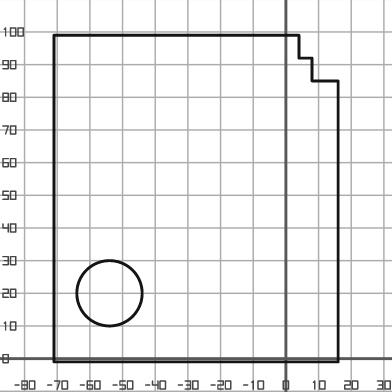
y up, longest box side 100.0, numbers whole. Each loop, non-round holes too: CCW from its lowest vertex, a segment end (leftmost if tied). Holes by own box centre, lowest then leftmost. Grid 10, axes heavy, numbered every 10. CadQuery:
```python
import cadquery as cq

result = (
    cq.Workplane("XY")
    .moveTo(-71.0, -1.0)
    .lineTo(16.0, -1.0)
    .lineTo(16.0, 85.0)
    .lineTo(8.0, 85.0)
    .lineTo(8.0, 92.0)
    .lineTo(4.0, 92.0)
    .lineTo(4.0, 99.0)
    .lineTo(-71.0, 99.0)
    .close()
    .moveTo(-54.0, 20.0)
    .circle(10.0)
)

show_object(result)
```